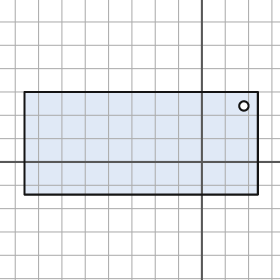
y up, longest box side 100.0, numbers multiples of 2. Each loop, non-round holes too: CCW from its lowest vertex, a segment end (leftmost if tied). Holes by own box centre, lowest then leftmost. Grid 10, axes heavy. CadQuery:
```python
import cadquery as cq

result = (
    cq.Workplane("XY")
    .moveTo(-76.0, -14.0)
    .lineTo(24.0, -14.0)
    .lineTo(24.0, 30.0)
    .lineTo(-76.0, 30.0)
    .close()
    .moveTo(18.0, 24.0)
    .circle(2.0)
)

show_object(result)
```